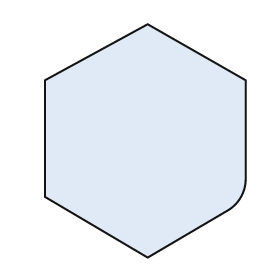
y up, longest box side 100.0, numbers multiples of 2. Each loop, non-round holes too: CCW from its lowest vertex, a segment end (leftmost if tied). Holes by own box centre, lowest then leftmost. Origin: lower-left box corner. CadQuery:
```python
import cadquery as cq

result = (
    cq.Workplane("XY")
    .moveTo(44.0, 0.0)
    .lineTo(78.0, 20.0)
    .threePointArc((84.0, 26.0), (86.0, 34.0))
    .lineTo(86.0, 76.0)
    .lineTo(44.0, 100.0)
    .lineTo(0.0, 76.0)
    .lineTo(0.0, 26.0)
    .close()
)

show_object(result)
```